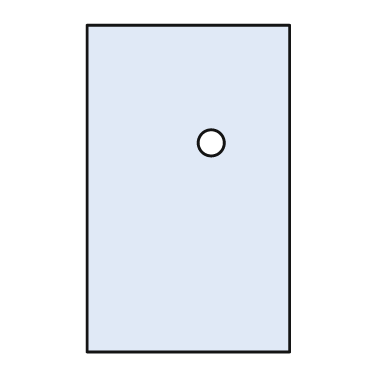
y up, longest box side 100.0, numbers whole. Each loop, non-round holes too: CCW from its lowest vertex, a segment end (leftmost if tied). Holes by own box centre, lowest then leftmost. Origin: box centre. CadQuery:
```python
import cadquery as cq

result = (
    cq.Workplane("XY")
    .moveTo(-31.0, -50.0)
    .lineTo(31.0, -50.0)
    .lineTo(31.0, 50.0)
    .lineTo(-31.0, 50.0)
    .close()
    .moveTo(7.0, 14.0)
    .circle(4.0)
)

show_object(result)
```